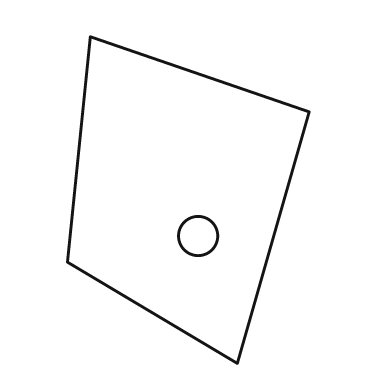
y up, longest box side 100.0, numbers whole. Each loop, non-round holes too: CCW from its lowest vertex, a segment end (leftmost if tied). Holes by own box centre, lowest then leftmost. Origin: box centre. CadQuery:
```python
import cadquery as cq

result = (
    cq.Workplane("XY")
    .moveTo(15.0, -50.0)
    .lineTo(37.0, 27.0)
    .lineTo(-30.0, 50.0)
    .lineTo(-37.0, -19.0)
    .close()
    .moveTo(3.0, -11.0)
    .circle(6.0)
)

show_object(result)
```